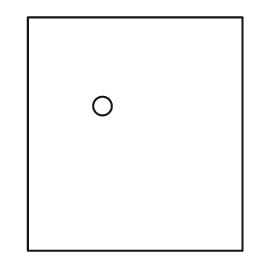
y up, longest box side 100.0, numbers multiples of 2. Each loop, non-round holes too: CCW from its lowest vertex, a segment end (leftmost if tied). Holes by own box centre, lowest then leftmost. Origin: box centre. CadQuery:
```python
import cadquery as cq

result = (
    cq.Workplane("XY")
    .moveTo(-46.0, -50.0)
    .lineTo(46.0, -50.0)
    .lineTo(46.0, 50.0)
    .lineTo(-46.0, 50.0)
    .close()
    .moveTo(-14.0, 12.0)
    .circle(4.0)
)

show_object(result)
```